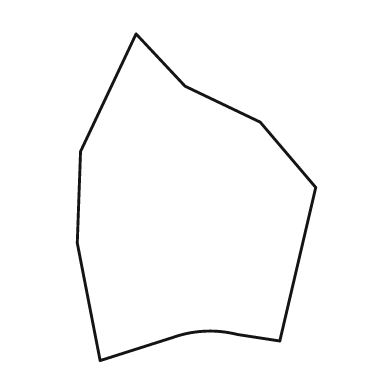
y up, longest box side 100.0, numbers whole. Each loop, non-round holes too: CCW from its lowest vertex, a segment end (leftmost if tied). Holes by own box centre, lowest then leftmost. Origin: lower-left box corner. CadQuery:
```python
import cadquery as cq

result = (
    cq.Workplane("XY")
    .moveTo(7.0, 0.0)
    .lineTo(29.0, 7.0)
    .threePointArc((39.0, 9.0), (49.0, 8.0))
    .lineTo(62.0, 6.0)
    .lineTo(73.0, 53.0)
    .lineTo(56.0, 73.0)
    .lineTo(33.0, 84.0)
    .lineTo(18.0, 100.0)
    .lineTo(1.0, 64.0)
    .lineTo(0.0, 36.0)
    .close()
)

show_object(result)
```